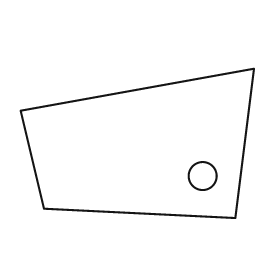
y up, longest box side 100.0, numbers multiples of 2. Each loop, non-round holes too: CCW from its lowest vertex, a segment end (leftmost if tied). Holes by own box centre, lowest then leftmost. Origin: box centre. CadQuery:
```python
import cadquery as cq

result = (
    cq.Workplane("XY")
    .moveTo(42.0, -32.0)
    .lineTo(50.0, 32.0)
    .lineTo(-50.0, 14.0)
    .lineTo(-40.0, -28.0)
    .close()
    .moveTo(28.0, -14.0)
    .circle(6.0)
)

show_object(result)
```